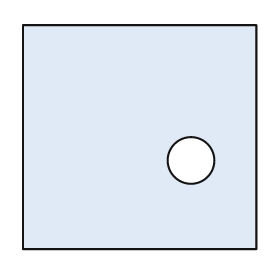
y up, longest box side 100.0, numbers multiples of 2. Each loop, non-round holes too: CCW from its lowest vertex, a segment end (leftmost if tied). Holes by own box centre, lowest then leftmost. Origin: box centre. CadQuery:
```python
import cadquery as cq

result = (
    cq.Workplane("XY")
    .moveTo(-50.0, -48.0)
    .lineTo(50.0, -48.0)
    .lineTo(50.0, 48.0)
    .lineTo(-50.0, 48.0)
    .close()
    .moveTo(22.0, -10.0)
    .circle(10.0)
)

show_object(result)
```